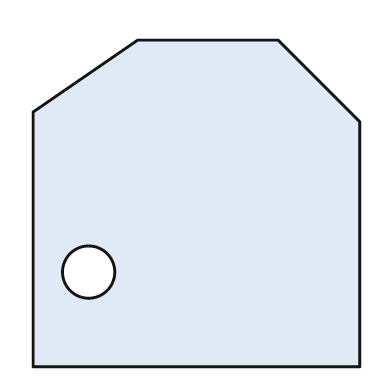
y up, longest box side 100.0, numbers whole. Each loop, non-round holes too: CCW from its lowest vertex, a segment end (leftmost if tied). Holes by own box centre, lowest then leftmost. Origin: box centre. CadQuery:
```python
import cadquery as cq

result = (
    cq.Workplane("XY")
    .moveTo(-50.0, -50.0)
    .lineTo(50.0, -50.0)
    .lineTo(50.0, 25.0)
    .lineTo(25.0, 50.0)
    .lineTo(-18.0, 50.0)
    .lineTo(-50.0, 28.0)
    .close()
    .moveTo(-33.0, -21.0)
    .circle(8.0)
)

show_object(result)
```